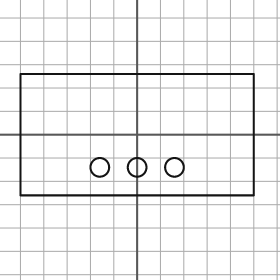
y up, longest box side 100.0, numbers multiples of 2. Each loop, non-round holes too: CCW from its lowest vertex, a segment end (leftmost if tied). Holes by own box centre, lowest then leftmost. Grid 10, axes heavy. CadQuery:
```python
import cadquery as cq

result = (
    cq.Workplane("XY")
    .moveTo(-50.0, -26.0)
    .lineTo(50.0, -26.0)
    .lineTo(50.0, 26.0)
    .lineTo(-50.0, 26.0)
    .close()
    .moveTo(-16.0, -14.0)
    .circle(4.0)
    .moveTo(0.0, -14.0)
    .circle(4.0)
    .moveTo(16.0, -14.0)
    .circle(4.0)
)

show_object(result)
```